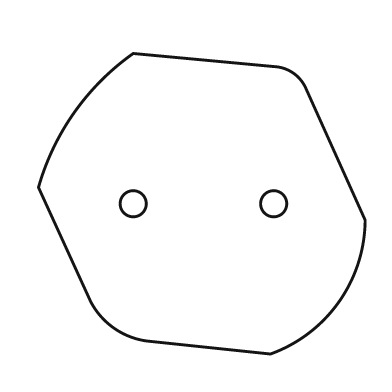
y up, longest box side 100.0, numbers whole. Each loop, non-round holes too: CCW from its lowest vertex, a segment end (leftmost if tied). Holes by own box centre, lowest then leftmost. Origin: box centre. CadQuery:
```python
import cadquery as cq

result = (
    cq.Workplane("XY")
    .moveTo(21.0, -46.0)
    .threePointArc((42.0, -30.0), (50.0, -5.0))
    .lineTo(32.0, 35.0)
    .threePointArc((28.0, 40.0), (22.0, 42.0))
    .lineTo(-21.0, 46.0)
    .threePointArc((-39.0, 28.0), (-50.0, 5.0))
    .lineTo(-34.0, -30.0)
    .threePointArc((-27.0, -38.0), (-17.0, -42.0))
    .close()
    .moveTo(-21.0, 0.0)
    .circle(4.0)
    .moveTo(22.0, 0.0)
    .circle(4.0)
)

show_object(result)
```